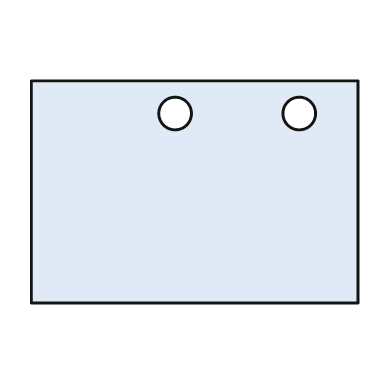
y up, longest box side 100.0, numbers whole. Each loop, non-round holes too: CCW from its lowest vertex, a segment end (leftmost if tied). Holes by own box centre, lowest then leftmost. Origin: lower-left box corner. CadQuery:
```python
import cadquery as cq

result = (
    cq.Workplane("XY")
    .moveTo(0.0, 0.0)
    .lineTo(100.0, 0.0)
    .lineTo(100.0, 68.0)
    .lineTo(0.0, 68.0)
    .close()
    .moveTo(44.0, 58.0)
    .circle(5.0)
    .moveTo(82.0, 58.0)
    .circle(5.0)
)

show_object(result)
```